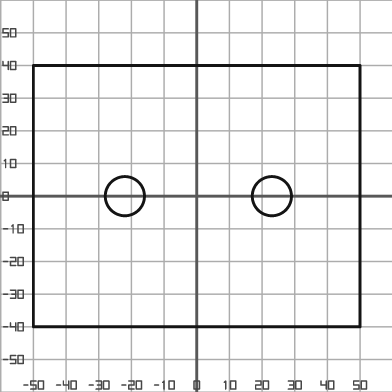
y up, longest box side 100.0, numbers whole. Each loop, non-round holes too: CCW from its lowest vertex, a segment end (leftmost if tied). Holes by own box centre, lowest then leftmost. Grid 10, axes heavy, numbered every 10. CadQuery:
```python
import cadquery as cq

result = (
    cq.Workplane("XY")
    .moveTo(-50.0, -40.0)
    .lineTo(50.0, -40.0)
    .lineTo(50.0, 40.0)
    .lineTo(-50.0, 40.0)
    .close()
    .moveTo(-22.0, 0.0)
    .circle(6.0)
    .moveTo(23.0, 0.0)
    .circle(6.0)
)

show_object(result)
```